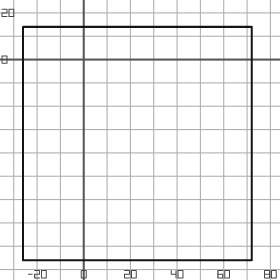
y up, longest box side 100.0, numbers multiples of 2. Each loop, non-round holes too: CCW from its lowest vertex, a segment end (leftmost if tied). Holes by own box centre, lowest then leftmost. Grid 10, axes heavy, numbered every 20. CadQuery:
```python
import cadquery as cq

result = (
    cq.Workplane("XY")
    .moveTo(-26.0, -86.0)
    .lineTo(72.0, -86.0)
    .lineTo(72.0, 14.0)
    .lineTo(-26.0, 14.0)
    .close()
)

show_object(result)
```